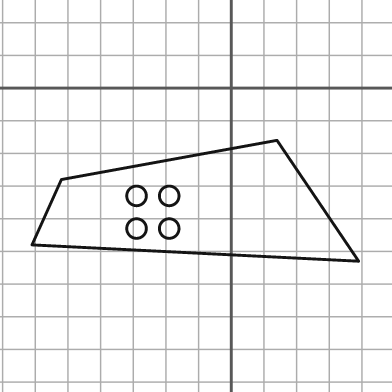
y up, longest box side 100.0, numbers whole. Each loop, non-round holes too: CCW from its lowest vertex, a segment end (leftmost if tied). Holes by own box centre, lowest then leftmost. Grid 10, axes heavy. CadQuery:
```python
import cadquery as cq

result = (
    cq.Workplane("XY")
    .moveTo(39.0, -53.0)
    .lineTo(14.0, -16.0)
    .lineTo(-52.0, -28.0)
    .lineTo(-61.0, -48.0)
    .close()
    .moveTo(-29.0, -43.0)
    .circle(3.0)
    .moveTo(-19.0, -43.0)
    .circle(3.0)
    .moveTo(-29.0, -33.0)
    .circle(3.0)
    .moveTo(-19.0, -33.0)
    .circle(3.0)
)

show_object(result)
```